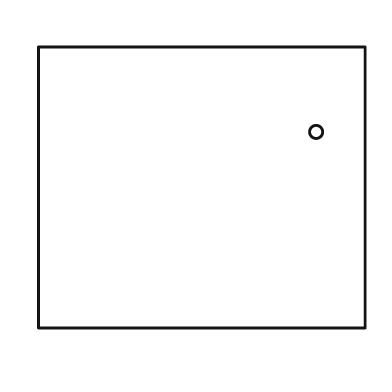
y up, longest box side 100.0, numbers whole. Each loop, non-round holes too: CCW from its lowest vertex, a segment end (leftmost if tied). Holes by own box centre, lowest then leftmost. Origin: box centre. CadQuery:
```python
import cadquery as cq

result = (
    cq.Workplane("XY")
    .moveTo(-50.0, -43.0)
    .lineTo(50.0, -43.0)
    .lineTo(50.0, 43.0)
    .lineTo(-50.0, 43.0)
    .close()
    .moveTo(35.0, 17.0)
    .circle(2.0)
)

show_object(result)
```